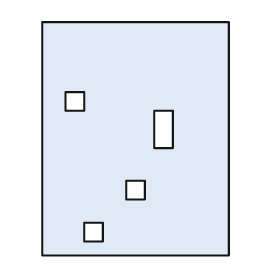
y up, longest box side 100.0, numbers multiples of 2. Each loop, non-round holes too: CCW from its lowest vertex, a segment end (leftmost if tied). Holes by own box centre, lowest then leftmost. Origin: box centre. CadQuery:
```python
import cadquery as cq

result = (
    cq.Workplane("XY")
    .moveTo(-40.0, -50.0)
    .lineTo(40.0, -50.0)
    .lineTo(40.0, 50.0)
    .lineTo(-40.0, 50.0)
    .close()
    .moveTo(-22.0, -44.0)
    .lineTo(-14.0, -44.0)
    .lineTo(-14.0, -36.0)
    .lineTo(-22.0, -36.0)
    .close()
    .moveTo(-4.0, -26.0)
    .lineTo(4.0, -26.0)
    .lineTo(4.0, -18.0)
    .lineTo(-4.0, -18.0)
    .close()
    .moveTo(8.0, -4.0)
    .lineTo(16.0, -4.0)
    .lineTo(16.0, 12.0)
    .lineTo(8.0, 12.0)
    .close()
    .moveTo(-30.0, 12.0)
    .lineTo(-22.0, 12.0)
    .lineTo(-22.0, 20.0)
    .lineTo(-30.0, 20.0)
    .close()
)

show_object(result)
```